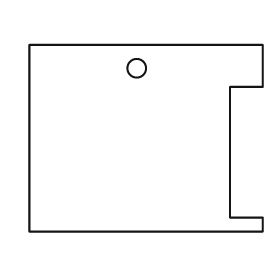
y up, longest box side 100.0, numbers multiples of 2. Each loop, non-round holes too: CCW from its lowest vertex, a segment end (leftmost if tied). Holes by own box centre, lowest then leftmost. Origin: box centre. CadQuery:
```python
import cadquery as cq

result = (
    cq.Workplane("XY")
    .moveTo(-50.0, -40.0)
    .lineTo(50.0, -40.0)
    .lineTo(50.0, -34.0)
    .lineTo(36.0, -34.0)
    .lineTo(36.0, 22.0)
    .lineTo(50.0, 22.0)
    .lineTo(50.0, 40.0)
    .lineTo(-50.0, 40.0)
    .close()
    .moveTo(-4.0, 30.0)
    .circle(4.0)
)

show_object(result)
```